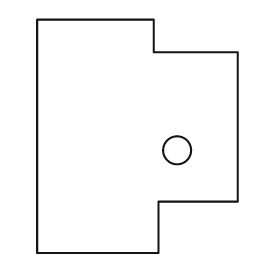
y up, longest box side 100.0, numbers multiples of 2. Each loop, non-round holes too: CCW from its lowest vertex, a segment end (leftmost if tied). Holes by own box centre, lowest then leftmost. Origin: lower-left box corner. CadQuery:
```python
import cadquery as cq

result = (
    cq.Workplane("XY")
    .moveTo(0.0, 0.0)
    .lineTo(52.0, 0.0)
    .lineTo(52.0, 22.0)
    .lineTo(86.0, 22.0)
    .lineTo(86.0, 86.0)
    .lineTo(50.0, 86.0)
    .lineTo(50.0, 100.0)
    .lineTo(0.0, 100.0)
    .close()
    .moveTo(60.0, 44.0)
    .circle(6.0)
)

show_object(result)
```